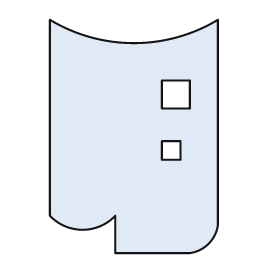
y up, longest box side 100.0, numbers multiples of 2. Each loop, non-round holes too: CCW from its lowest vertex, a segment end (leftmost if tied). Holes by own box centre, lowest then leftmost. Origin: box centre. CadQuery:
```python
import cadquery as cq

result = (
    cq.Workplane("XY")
    .moveTo(-8.0, -50.0)
    .lineTo(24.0, -50.0)
    .threePointArc((32.0, -46.0), (36.0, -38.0))
    .lineTo(36.0, 50.0)
    .threePointArc((0.0, 40.0), (-36.0, 50.0))
    .lineTo(-36.0, -34.0)
    .threePointArc((-22.0, -40.0), (-8.0, -34.0))
    .close()
    .moveTo(12.0, -10.0)
    .lineTo(20.0, -10.0)
    .lineTo(20.0, -2.0)
    .lineTo(12.0, -2.0)
    .close()
    .moveTo(12.0, 12.0)
    .lineTo(24.0, 12.0)
    .lineTo(24.0, 24.0)
    .lineTo(12.0, 24.0)
    .close()
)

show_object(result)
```